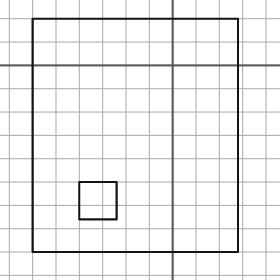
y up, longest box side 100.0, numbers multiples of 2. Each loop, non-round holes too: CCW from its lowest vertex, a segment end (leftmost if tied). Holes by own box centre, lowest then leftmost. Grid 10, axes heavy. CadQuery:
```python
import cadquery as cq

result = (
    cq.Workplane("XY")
    .moveTo(-60.0, -80.0)
    .lineTo(28.0, -80.0)
    .lineTo(28.0, 20.0)
    .lineTo(-60.0, 20.0)
    .close()
    .moveTo(-40.0, -66.0)
    .lineTo(-24.0, -66.0)
    .lineTo(-24.0, -50.0)
    .lineTo(-40.0, -50.0)
    .close()
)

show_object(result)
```